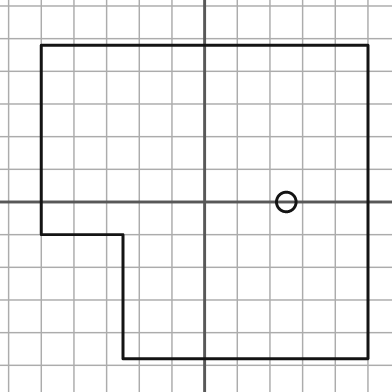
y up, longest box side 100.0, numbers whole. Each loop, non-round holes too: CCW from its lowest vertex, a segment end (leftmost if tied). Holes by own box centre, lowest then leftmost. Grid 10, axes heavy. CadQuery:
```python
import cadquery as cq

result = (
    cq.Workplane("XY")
    .moveTo(-25.0, -48.0)
    .lineTo(50.0, -48.0)
    .lineTo(50.0, 48.0)
    .lineTo(-50.0, 48.0)
    .lineTo(-50.0, -10.0)
    .lineTo(-25.0, -10.0)
    .close()
    .moveTo(25.0, 0.0)
    .circle(3.0)
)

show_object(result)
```